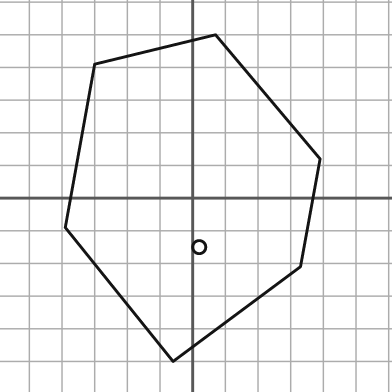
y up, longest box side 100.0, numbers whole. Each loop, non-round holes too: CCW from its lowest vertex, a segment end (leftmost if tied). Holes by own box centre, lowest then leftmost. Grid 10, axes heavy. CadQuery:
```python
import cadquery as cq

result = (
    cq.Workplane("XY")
    .moveTo(-6.0, -50.0)
    .lineTo(33.0, -21.0)
    .lineTo(39.0, 12.0)
    .lineTo(7.0, 50.0)
    .lineTo(-30.0, 41.0)
    .lineTo(-39.0, -9.0)
    .close()
    .moveTo(2.0, -15.0)
    .circle(2.0)
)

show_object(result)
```